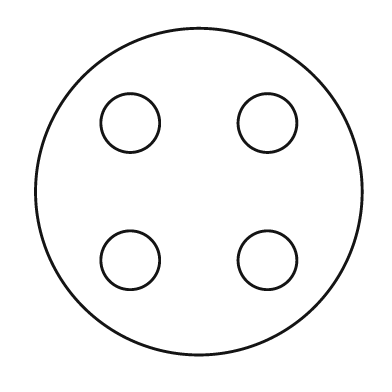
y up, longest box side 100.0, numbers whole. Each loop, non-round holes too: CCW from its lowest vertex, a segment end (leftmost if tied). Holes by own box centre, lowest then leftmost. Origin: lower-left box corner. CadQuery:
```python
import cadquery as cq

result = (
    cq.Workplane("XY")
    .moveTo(50.0, 50.0)
    .circle(50.0)
    .moveTo(29.0, 29.0)
    .circle(9.0)
    .moveTo(71.0, 29.0)
    .circle(9.0)
    .moveTo(29.0, 71.0)
    .circle(9.0)
    .moveTo(71.0, 71.0)
    .circle(9.0)
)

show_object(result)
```